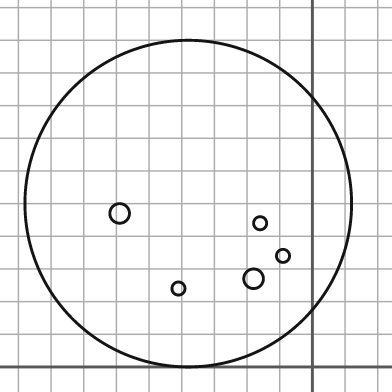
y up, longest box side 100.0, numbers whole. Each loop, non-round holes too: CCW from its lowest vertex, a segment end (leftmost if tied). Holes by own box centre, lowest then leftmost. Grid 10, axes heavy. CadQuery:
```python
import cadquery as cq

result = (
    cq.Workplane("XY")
    .moveTo(-38.0, 50.0)
    .circle(50.0)
    .moveTo(-41.0, 24.0)
    .circle(2.0)
    .moveTo(-18.0, 27.0)
    .circle(3.0)
    .moveTo(-9.0, 34.0)
    .circle(2.0)
    .moveTo(-16.0, 44.0)
    .circle(2.0)
    .moveTo(-59.0, 47.0)
    .circle(3.0)
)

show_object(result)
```